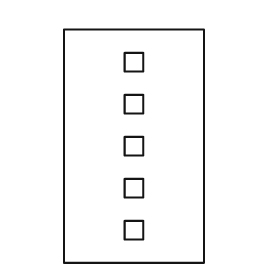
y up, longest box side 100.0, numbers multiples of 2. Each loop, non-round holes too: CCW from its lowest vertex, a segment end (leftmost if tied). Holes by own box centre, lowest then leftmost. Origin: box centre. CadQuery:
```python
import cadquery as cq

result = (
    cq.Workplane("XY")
    .moveTo(-30.0, -50.0)
    .lineTo(30.0, -50.0)
    .lineTo(30.0, 50.0)
    .lineTo(-30.0, 50.0)
    .close()
    .moveTo(-4.0, -40.0)
    .lineTo(4.0, -40.0)
    .lineTo(4.0, -32.0)
    .lineTo(-4.0, -32.0)
    .close()
    .moveTo(-4.0, -22.0)
    .lineTo(4.0, -22.0)
    .lineTo(4.0, -14.0)
    .lineTo(-4.0, -14.0)
    .close()
    .moveTo(-4.0, -4.0)
    .lineTo(4.0, -4.0)
    .lineTo(4.0, 4.0)
    .lineTo(-4.0, 4.0)
    .close()
    .moveTo(-4.0, 14.0)
    .lineTo(4.0, 14.0)
    .lineTo(4.0, 22.0)
    .lineTo(-4.0, 22.0)
    .close()
    .moveTo(-4.0, 32.0)
    .lineTo(4.0, 32.0)
    .lineTo(4.0, 40.0)
    .lineTo(-4.0, 40.0)
    .close()
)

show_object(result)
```